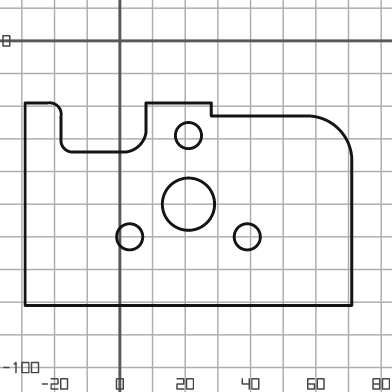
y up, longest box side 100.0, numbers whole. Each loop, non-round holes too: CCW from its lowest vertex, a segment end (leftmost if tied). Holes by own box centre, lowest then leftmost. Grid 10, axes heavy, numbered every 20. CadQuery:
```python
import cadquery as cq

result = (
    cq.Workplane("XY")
    .moveTo(-29.0, -81.0)
    .lineTo(71.0, -81.0)
    .lineTo(71.0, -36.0)
    .threePointArc((67.0, -27.0), (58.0, -23.0))
    .lineTo(28.0, -23.0)
    .lineTo(28.0, -19.0)
    .lineTo(8.0, -19.0)
    .lineTo(8.0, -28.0)
    .threePointArc((6.0, -32.0), (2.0, -34.0))
    .lineTo(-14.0, -34.0)
    .threePointArc((-17.0, -33.0), (-18.0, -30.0))
    .lineTo(-18.0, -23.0)
    .threePointArc((-19.0, -20.0), (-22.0, -19.0))
    .lineTo(-29.0, -19.0)
    .close()
    .moveTo(3.0, -60.0)
    .circle(4.0)
    .moveTo(39.0, -60.0)
    .circle(4.0)
    .moveTo(21.0, -50.0)
    .circle(8.0)
    .moveTo(21.0, -29.0)
    .circle(4.0)
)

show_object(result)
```